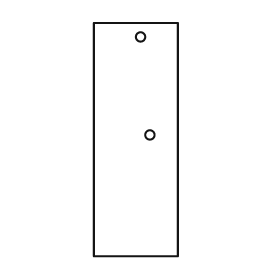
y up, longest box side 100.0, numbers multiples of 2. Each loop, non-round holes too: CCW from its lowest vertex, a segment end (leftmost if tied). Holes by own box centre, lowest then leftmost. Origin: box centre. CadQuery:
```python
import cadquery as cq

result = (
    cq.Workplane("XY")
    .moveTo(-18.0, -50.0)
    .lineTo(18.0, -50.0)
    .lineTo(18.0, 50.0)
    .lineTo(-18.0, 50.0)
    .close()
    .moveTo(6.0, 2.0)
    .circle(2.0)
    .moveTo(2.0, 44.0)
    .circle(2.0)
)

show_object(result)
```